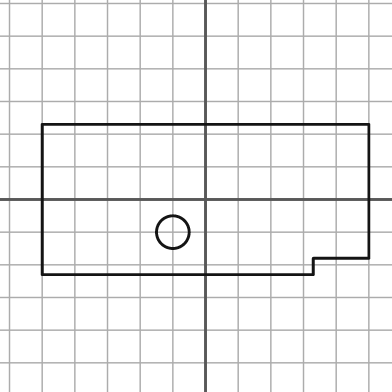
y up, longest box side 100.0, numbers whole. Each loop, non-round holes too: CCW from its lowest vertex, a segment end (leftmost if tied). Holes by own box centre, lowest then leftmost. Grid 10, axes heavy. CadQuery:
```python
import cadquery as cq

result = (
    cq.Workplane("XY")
    .moveTo(-50.0, -23.0)
    .lineTo(33.0, -23.0)
    .lineTo(33.0, -18.0)
    .lineTo(50.0, -18.0)
    .lineTo(50.0, 23.0)
    .lineTo(-50.0, 23.0)
    .close()
    .moveTo(-10.0, -10.0)
    .circle(5.0)
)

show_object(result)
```